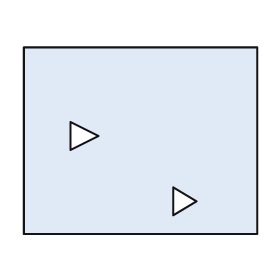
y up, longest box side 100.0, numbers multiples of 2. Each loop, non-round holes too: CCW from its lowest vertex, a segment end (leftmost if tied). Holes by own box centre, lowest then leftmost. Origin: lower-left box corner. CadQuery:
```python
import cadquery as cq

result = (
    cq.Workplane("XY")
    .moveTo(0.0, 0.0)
    .lineTo(100.0, 0.0)
    .lineTo(100.0, 80.0)
    .lineTo(0.0, 80.0)
    .close()
    .moveTo(64.0, 8.0)
    .lineTo(74.0, 14.0)
    .lineTo(64.0, 20.0)
    .close()
    .moveTo(20.0, 36.0)
    .lineTo(32.0, 42.0)
    .lineTo(20.0, 48.0)
    .close()
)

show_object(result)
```